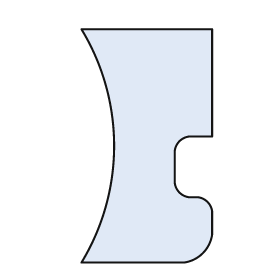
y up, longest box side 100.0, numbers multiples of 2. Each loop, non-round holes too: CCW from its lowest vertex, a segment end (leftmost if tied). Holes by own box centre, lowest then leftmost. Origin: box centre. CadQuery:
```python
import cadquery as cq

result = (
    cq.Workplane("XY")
    .moveTo(-28.0, -50.0)
    .lineTo(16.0, -50.0)
    .threePointArc((24.0, -46.0), (28.0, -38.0))
    .lineTo(28.0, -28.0)
    .threePointArc((26.0, -24.0), (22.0, -22.0))
    .lineTo(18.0, -22.0)
    .threePointArc((14.0, -20.0), (12.0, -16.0))
    .lineTo(12.0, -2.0)
    .threePointArc((14.0, 2.0), (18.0, 4.0))
    .lineTo(28.0, 4.0)
    .lineTo(28.0, 50.0)
    .lineTo(-28.0, 50.0)
    .threePointArc((-14.0, 0.0), (-28.0, -50.0))
    .close()
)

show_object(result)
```